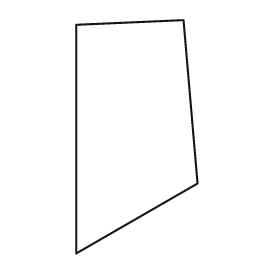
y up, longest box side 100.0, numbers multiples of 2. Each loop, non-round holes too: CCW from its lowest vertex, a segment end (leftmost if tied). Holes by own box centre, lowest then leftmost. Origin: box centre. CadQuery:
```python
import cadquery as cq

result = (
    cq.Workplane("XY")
    .moveTo(-26.0, -50.0)
    .lineTo(26.0, -20.0)
    .lineTo(20.0, 50.0)
    .lineTo(-26.0, 48.0)
    .close()
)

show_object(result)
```